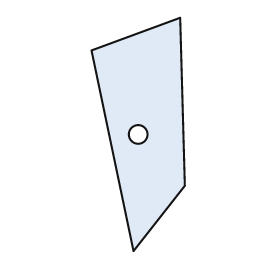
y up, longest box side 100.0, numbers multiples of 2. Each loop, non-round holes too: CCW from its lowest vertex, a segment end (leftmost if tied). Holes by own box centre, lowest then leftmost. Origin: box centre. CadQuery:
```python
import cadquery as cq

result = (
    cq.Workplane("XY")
    .moveTo(-2.0, -50.0)
    .lineTo(20.0, -22.0)
    .lineTo(18.0, 50.0)
    .lineTo(-20.0, 36.0)
    .close()
    .moveTo(0.0, 0.0)
    .circle(4.0)
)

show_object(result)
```